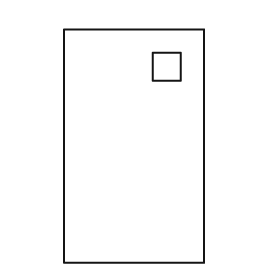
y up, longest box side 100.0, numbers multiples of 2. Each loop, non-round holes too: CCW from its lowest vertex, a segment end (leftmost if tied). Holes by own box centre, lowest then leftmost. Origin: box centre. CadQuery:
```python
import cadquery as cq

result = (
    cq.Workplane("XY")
    .moveTo(-30.0, -50.0)
    .lineTo(30.0, -50.0)
    .lineTo(30.0, 50.0)
    .lineTo(-30.0, 50.0)
    .close()
    .moveTo(8.0, 28.0)
    .lineTo(20.0, 28.0)
    .lineTo(20.0, 40.0)
    .lineTo(8.0, 40.0)
    .close()
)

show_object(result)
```